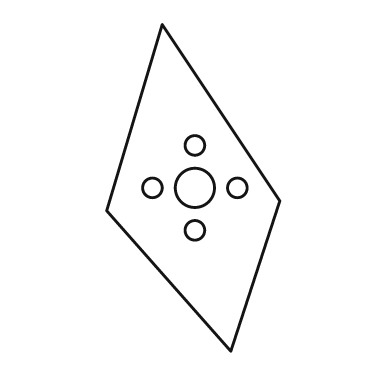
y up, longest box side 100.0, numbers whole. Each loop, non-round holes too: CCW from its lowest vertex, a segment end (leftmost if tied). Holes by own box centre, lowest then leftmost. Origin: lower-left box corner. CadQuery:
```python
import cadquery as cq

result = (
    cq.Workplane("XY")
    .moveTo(38.0, 0.0)
    .lineTo(53.0, 46.0)
    .lineTo(17.0, 100.0)
    .lineTo(0.0, 43.0)
    .close()
    .moveTo(27.0, 37.0)
    .circle(3.0)
    .moveTo(14.0, 50.0)
    .circle(3.0)
    .moveTo(27.0, 50.0)
    .circle(6.0)
    .moveTo(40.0, 50.0)
    .circle(3.0)
    .moveTo(27.0, 63.0)
    .circle(3.0)
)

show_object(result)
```